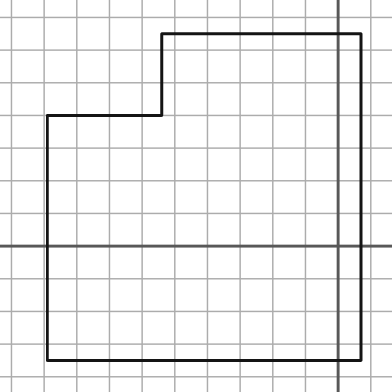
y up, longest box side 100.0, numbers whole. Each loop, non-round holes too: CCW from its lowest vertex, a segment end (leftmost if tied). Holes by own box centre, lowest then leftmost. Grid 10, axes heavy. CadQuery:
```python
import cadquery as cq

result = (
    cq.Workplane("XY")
    .moveTo(-89.0, -35.0)
    .lineTo(7.0, -35.0)
    .lineTo(7.0, 65.0)
    .lineTo(-54.0, 65.0)
    .lineTo(-54.0, 40.0)
    .lineTo(-89.0, 40.0)
    .close()
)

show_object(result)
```